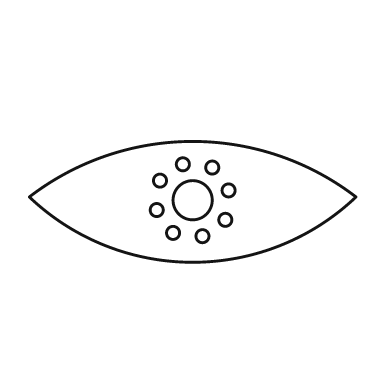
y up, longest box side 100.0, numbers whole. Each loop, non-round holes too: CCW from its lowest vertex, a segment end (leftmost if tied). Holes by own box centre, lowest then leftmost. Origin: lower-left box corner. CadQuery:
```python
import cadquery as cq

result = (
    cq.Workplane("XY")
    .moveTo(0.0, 20.0)
    .threePointArc((50.0, 0.0), (100.0, 20.0))
    .threePointArc((50.0, 37.0), (0.0, 20.0))
    .close()
    .moveTo(53.0, 8.0)
    .circle(2.0)
    .moveTo(44.0, 9.0)
    .circle(2.0)
    .moveTo(60.0, 13.0)
    .circle(2.0)
    .moveTo(39.0, 16.0)
    .circle(2.0)
    .moveTo(50.0, 19.0)
    .circle(6.0)
    .moveTo(61.0, 22.0)
    .circle(2.0)
    .moveTo(40.0, 25.0)
    .circle(2.0)
    .moveTo(56.0, 29.0)
    .circle(2.0)
    .moveTo(47.0, 30.0)
    .circle(2.0)
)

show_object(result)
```